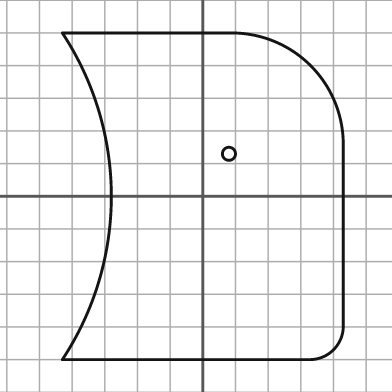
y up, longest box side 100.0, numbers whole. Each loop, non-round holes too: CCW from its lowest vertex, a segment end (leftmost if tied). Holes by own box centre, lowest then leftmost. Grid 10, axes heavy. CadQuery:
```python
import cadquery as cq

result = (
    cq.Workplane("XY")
    .moveTo(-43.0, -50.0)
    .lineTo(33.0, -50.0)
    .threePointArc((40.0, -47.0), (43.0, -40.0))
    .lineTo(43.0, 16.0)
    .threePointArc((33.0, 40.0), (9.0, 50.0))
    .lineTo(-43.0, 50.0)
    .threePointArc((-28.0, 0.0), (-43.0, -50.0))
    .close()
    .moveTo(8.0, 13.0)
    .circle(2.0)
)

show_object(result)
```